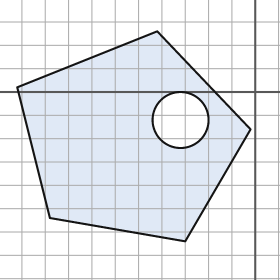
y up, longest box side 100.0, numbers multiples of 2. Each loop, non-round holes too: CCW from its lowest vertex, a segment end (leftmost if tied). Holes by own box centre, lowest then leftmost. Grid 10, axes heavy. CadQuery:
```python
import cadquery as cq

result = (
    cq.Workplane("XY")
    .moveTo(-30.0, -64.0)
    .lineTo(-2.0, -16.0)
    .lineTo(-42.0, 26.0)
    .lineTo(-102.0, 2.0)
    .lineTo(-88.0, -54.0)
    .close()
    .moveTo(-32.0, -12.0)
    .circle(12.0)
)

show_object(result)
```